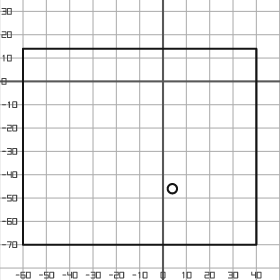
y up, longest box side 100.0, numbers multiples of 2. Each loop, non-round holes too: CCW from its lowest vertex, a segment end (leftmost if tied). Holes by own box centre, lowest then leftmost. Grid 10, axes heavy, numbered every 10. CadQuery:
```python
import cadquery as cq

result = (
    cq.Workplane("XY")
    .moveTo(-60.0, -70.0)
    .lineTo(40.0, -70.0)
    .lineTo(40.0, 14.0)
    .lineTo(-60.0, 14.0)
    .close()
    .moveTo(4.0, -46.0)
    .circle(2.0)
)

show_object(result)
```